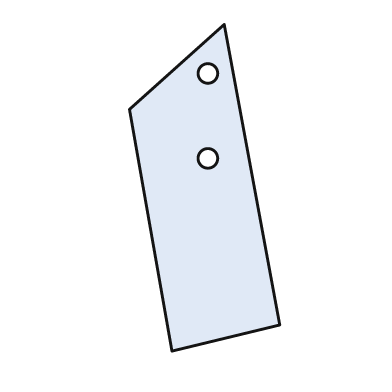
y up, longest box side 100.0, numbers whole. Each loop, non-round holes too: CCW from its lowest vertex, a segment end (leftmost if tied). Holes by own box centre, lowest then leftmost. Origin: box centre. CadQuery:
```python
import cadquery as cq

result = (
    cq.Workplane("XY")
    .moveTo(-10.0, -50.0)
    .lineTo(23.0, -42.0)
    .lineTo(6.0, 50.0)
    .lineTo(-23.0, 24.0)
    .close()
    .moveTo(1.0, 9.0)
    .circle(3.0)
    .moveTo(1.0, 35.0)
    .circle(3.0)
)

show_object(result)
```